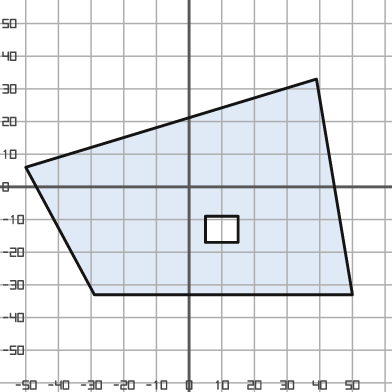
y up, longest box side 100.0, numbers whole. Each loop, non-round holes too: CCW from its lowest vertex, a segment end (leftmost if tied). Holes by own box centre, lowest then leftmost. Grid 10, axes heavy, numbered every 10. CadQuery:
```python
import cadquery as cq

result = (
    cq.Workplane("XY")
    .moveTo(-29.0, -33.0)
    .lineTo(50.0, -33.0)
    .lineTo(39.0, 33.0)
    .lineTo(-50.0, 6.0)
    .close()
    .moveTo(5.0, -17.0)
    .lineTo(15.0, -17.0)
    .lineTo(15.0, -9.0)
    .lineTo(5.0, -9.0)
    .close()
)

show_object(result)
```